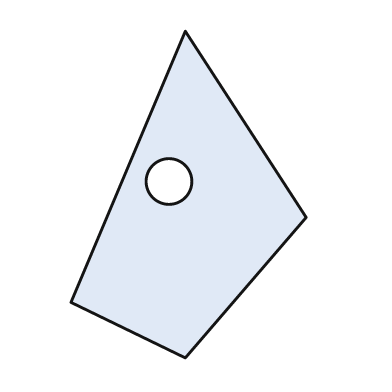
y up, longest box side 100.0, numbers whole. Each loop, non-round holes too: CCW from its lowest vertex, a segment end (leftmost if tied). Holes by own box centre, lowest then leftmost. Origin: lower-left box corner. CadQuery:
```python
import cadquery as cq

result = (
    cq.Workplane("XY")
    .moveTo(35.0, 0.0)
    .lineTo(72.0, 43.0)
    .lineTo(35.0, 100.0)
    .lineTo(0.0, 17.0)
    .close()
    .moveTo(30.0, 54.0)
    .circle(7.0)
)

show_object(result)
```